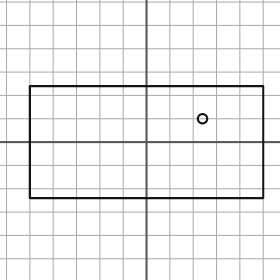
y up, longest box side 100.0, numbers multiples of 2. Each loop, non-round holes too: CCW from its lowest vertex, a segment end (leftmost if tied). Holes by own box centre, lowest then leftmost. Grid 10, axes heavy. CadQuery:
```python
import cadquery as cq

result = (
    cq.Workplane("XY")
    .moveTo(-50.0, -24.0)
    .lineTo(50.0, -24.0)
    .lineTo(50.0, 24.0)
    .lineTo(-50.0, 24.0)
    .close()
    .moveTo(24.0, 10.0)
    .circle(2.0)
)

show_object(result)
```